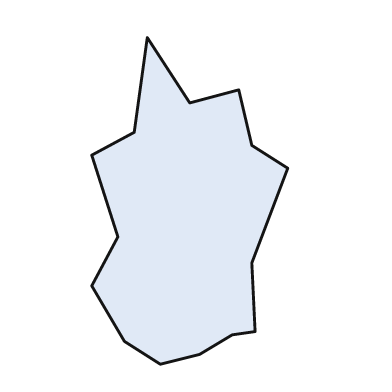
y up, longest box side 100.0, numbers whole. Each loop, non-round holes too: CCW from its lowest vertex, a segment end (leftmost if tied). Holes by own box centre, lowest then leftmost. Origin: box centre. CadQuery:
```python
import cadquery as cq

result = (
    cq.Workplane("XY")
    .moveTo(-9.0, -50.0)
    .lineTo(3.0, -47.0)
    .lineTo(13.0, -41.0)
    .lineTo(20.0, -40.0)
    .lineTo(19.0, -19.0)
    .lineTo(30.0, 10.0)
    .lineTo(19.0, 17.0)
    .lineTo(15.0, 34.0)
    .lineTo(0.0, 30.0)
    .lineTo(-13.0, 50.0)
    .lineTo(-17.0, 21.0)
    .lineTo(-30.0, 14.0)
    .lineTo(-22.0, -11.0)
    .lineTo(-30.0, -26.0)
    .lineTo(-20.0, -43.0)
    .close()
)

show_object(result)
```